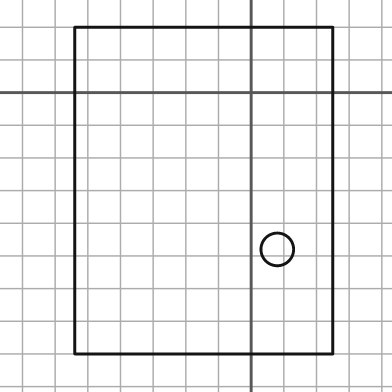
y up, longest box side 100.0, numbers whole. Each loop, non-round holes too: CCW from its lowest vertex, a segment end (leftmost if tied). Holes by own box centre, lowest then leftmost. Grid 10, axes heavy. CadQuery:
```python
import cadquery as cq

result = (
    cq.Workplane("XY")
    .moveTo(-54.0, -80.0)
    .lineTo(25.0, -80.0)
    .lineTo(25.0, 20.0)
    .lineTo(-54.0, 20.0)
    .close()
    .moveTo(8.0, -48.0)
    .circle(5.0)
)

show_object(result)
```